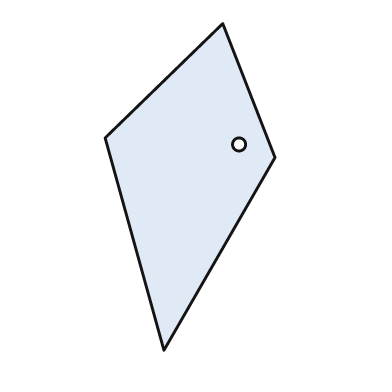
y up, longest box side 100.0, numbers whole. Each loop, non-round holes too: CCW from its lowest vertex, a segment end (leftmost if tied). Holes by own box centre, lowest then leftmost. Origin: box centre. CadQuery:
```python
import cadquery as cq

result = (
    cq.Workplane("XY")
    .moveTo(-8.0, -50.0)
    .lineTo(26.0, 9.0)
    .lineTo(10.0, 50.0)
    .lineTo(-26.0, 15.0)
    .close()
    .moveTo(15.0, 13.0)
    .circle(2.0)
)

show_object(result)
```